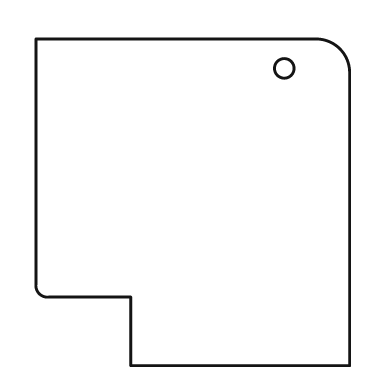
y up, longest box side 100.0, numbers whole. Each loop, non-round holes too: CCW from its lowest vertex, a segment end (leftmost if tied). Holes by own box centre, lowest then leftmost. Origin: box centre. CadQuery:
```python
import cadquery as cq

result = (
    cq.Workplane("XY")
    .moveTo(-19.0, -50.0)
    .lineTo(48.0, -50.0)
    .lineTo(48.0, 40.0)
    .threePointArc((45.0, 47.0), (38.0, 50.0))
    .lineTo(-48.0, 50.0)
    .lineTo(-48.0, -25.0)
    .threePointArc((-47.0, -28.0), (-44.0, -29.0))
    .lineTo(-19.0, -29.0)
    .close()
    .moveTo(28.0, 41.0)
    .circle(3.0)
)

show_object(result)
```